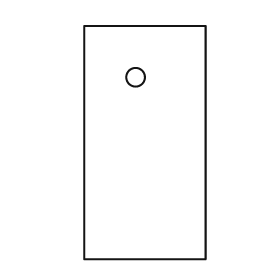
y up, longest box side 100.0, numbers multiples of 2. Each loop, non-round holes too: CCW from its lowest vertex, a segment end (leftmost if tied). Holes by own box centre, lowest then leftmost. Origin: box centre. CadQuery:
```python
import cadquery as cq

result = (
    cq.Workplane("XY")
    .moveTo(-26.0, -50.0)
    .lineTo(26.0, -50.0)
    .lineTo(26.0, 50.0)
    .lineTo(-26.0, 50.0)
    .close()
    .moveTo(-4.0, 28.0)
    .circle(4.0)
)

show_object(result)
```